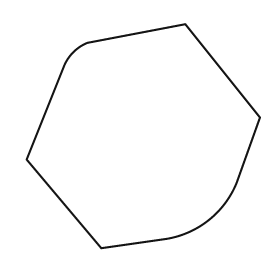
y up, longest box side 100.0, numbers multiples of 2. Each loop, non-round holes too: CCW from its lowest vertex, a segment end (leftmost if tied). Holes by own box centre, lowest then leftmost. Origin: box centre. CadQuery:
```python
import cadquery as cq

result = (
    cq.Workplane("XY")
    .moveTo(-18.0, -48.0)
    .lineTo(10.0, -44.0)
    .threePointArc((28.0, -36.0), (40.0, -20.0))
    .lineTo(50.0, 8.0)
    .lineTo(18.0, 48.0)
    .lineTo(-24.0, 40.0)
    .threePointArc((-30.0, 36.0), (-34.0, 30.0))
    .lineTo(-50.0, -10.0)
    .close()
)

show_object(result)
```